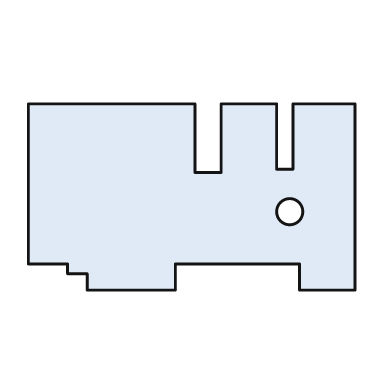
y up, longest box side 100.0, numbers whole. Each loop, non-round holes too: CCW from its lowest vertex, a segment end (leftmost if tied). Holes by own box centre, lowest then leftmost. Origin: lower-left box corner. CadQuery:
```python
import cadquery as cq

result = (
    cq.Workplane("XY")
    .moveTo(18.0, 0.0)
    .lineTo(45.0, 0.0)
    .lineTo(45.0, 8.0)
    .lineTo(83.0, 8.0)
    .lineTo(83.0, 0.0)
    .lineTo(100.0, 0.0)
    .lineTo(100.0, 57.0)
    .lineTo(81.0, 57.0)
    .lineTo(81.0, 37.0)
    .lineTo(76.0, 37.0)
    .lineTo(76.0, 57.0)
    .lineTo(59.0, 57.0)
    .lineTo(59.0, 36.0)
    .lineTo(51.0, 36.0)
    .lineTo(51.0, 57.0)
    .lineTo(0.0, 57.0)
    .lineTo(0.0, 8.0)
    .lineTo(12.0, 8.0)
    .lineTo(12.0, 5.0)
    .lineTo(18.0, 5.0)
    .close()
    .moveTo(80.0, 24.0)
    .circle(4.0)
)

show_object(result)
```